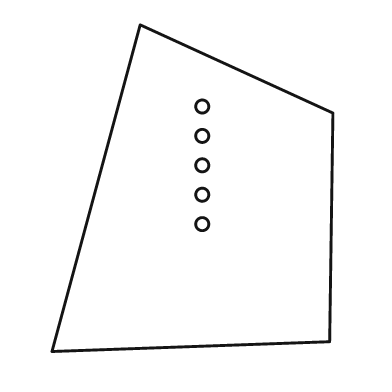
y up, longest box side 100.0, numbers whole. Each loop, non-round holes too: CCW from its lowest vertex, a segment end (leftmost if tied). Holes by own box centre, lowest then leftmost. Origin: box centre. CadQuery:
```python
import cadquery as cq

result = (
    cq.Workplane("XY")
    .moveTo(-43.0, -50.0)
    .lineTo(42.0, -47.0)
    .lineTo(43.0, 23.0)
    .lineTo(-16.0, 50.0)
    .close()
    .moveTo(3.0, -11.0)
    .circle(2.0)
    .moveTo(3.0, -2.0)
    .circle(2.0)
    .moveTo(3.0, 7.0)
    .circle(2.0)
    .moveTo(3.0, 16.0)
    .circle(2.0)
    .moveTo(3.0, 25.0)
    .circle(2.0)
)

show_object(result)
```